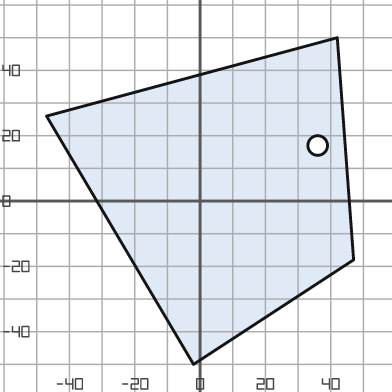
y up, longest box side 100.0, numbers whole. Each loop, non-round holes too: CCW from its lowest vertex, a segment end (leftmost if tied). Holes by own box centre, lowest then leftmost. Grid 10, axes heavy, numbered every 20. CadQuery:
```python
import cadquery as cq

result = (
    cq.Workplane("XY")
    .moveTo(-2.0, -50.0)
    .lineTo(47.0, -18.0)
    .lineTo(42.0, 50.0)
    .lineTo(-47.0, 26.0)
    .close()
    .moveTo(36.0, 17.0)
    .circle(3.0)
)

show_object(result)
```